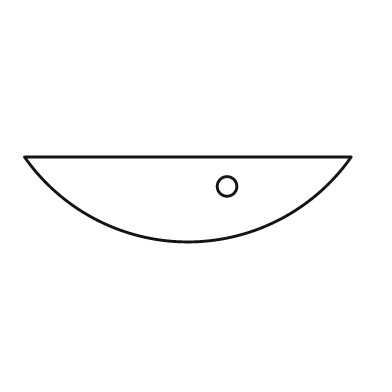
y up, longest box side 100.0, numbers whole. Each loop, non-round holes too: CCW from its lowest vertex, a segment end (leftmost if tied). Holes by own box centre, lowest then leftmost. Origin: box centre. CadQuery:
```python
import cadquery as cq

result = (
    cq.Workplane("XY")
    .moveTo(-50.0, 13.0)
    .threePointArc((0.0, -13.0), (50.0, 13.0))
    .close()
    .moveTo(12.0, 4.0)
    .circle(3.0)
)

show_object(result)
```